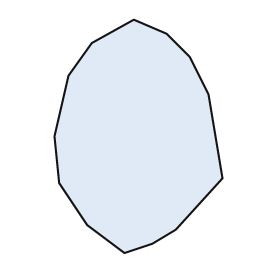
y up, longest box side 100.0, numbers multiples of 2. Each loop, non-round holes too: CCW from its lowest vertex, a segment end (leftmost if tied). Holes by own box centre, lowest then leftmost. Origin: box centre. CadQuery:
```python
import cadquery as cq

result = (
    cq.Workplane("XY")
    .moveTo(-6.0, -50.0)
    .lineTo(6.0, -46.0)
    .lineTo(16.0, -40.0)
    .lineTo(36.0, -18.0)
    .lineTo(30.0, 18.0)
    .lineTo(22.0, 34.0)
    .lineTo(12.0, 44.0)
    .lineTo(-2.0, 50.0)
    .lineTo(-20.0, 40.0)
    .lineTo(-30.0, 26.0)
    .lineTo(-36.0, 0.0)
    .lineTo(-34.0, -20.0)
    .lineTo(-22.0, -38.0)
    .close()
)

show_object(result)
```